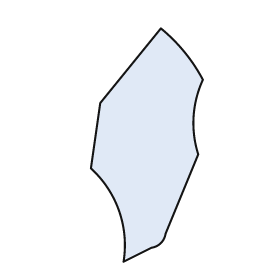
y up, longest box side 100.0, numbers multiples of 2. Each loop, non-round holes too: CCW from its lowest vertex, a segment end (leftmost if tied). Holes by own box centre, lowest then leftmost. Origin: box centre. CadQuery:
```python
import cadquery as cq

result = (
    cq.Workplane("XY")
    .moveTo(-10.0, -50.0)
    .lineTo(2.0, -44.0)
    .threePointArc((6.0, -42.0), (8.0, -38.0))
    .lineTo(22.0, -4.0)
    .threePointArc((20.0, 12.0), (24.0, 28.0))
    .threePointArc((16.0, 40.0), (6.0, 50.0))
    .lineTo(-20.0, 18.0)
    .lineTo(-24.0, -10.0)
    .threePointArc((-12.0, -28.0), (-10.0, -50.0))
    .close()
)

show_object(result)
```